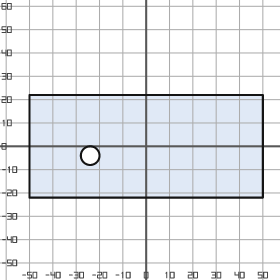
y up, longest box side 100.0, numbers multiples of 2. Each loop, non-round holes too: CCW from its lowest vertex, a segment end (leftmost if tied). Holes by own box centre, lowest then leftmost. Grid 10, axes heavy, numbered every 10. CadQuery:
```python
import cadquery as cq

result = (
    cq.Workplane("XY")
    .moveTo(-50.0, -22.0)
    .lineTo(50.0, -22.0)
    .lineTo(50.0, 22.0)
    .lineTo(-50.0, 22.0)
    .close()
    .moveTo(-24.0, -4.0)
    .circle(4.0)
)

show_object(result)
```